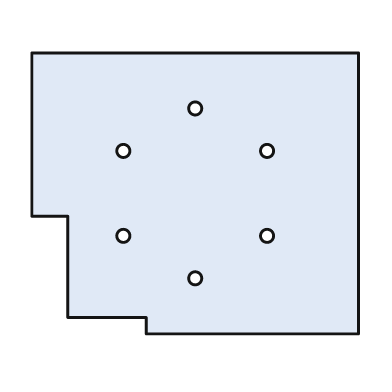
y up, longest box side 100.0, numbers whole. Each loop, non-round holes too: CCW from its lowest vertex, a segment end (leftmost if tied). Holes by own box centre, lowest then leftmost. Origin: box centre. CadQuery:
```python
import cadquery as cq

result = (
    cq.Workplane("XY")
    .moveTo(-15.0, -43.0)
    .lineTo(50.0, -43.0)
    .lineTo(50.0, 43.0)
    .lineTo(-50.0, 43.0)
    .lineTo(-50.0, -7.0)
    .lineTo(-39.0, -7.0)
    .lineTo(-39.0, -38.0)
    .lineTo(-15.0, -38.0)
    .close()
    .moveTo(0.0, -26.0)
    .circle(2.0)
    .moveTo(-22.0, -13.0)
    .circle(2.0)
    .moveTo(22.0, -13.0)
    .circle(2.0)
    .moveTo(-22.0, 13.0)
    .circle(2.0)
    .moveTo(22.0, 13.0)
    .circle(2.0)
    .moveTo(0.0, 26.0)
    .circle(2.0)
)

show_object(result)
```